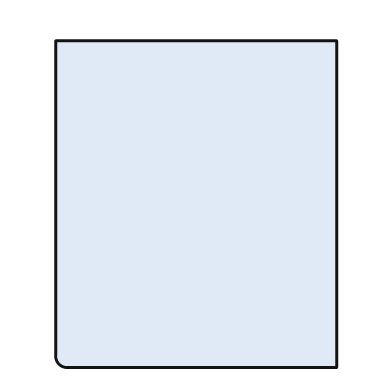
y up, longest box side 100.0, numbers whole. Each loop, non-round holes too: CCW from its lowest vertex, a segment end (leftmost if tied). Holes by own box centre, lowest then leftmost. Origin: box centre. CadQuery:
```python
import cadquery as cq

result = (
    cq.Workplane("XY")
    .moveTo(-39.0, -50.0)
    .lineTo(43.0, -50.0)
    .lineTo(43.0, 50.0)
    .lineTo(-43.0, 50.0)
    .lineTo(-43.0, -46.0)
    .threePointArc((-42.0, -49.0), (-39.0, -50.0))
    .close()
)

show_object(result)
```